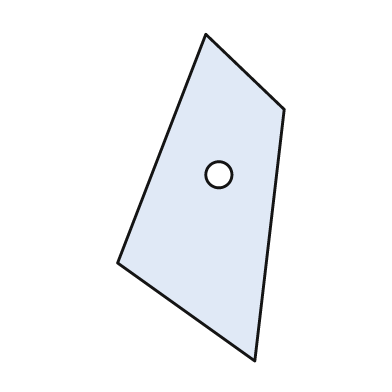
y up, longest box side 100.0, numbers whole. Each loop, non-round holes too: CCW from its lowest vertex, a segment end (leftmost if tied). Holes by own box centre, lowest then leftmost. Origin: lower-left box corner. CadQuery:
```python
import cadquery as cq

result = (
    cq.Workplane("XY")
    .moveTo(42.0, 0.0)
    .lineTo(51.0, 77.0)
    .lineTo(27.0, 100.0)
    .lineTo(0.0, 30.0)
    .close()
    .moveTo(31.0, 57.0)
    .circle(4.0)
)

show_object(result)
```